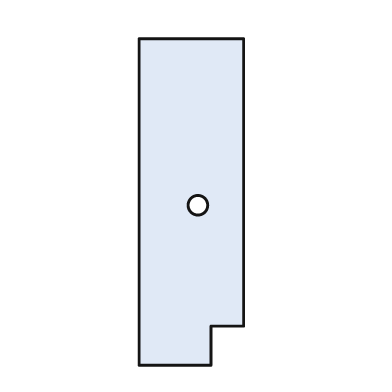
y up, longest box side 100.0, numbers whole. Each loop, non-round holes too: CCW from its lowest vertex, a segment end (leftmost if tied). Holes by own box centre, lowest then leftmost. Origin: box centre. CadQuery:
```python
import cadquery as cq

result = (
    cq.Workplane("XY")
    .moveTo(-16.0, -50.0)
    .lineTo(6.0, -50.0)
    .lineTo(6.0, -38.0)
    .lineTo(16.0, -38.0)
    .lineTo(16.0, 50.0)
    .lineTo(-16.0, 50.0)
    .close()
    .moveTo(2.0, -1.0)
    .circle(3.0)
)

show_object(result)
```